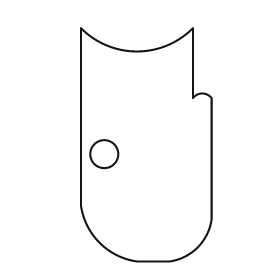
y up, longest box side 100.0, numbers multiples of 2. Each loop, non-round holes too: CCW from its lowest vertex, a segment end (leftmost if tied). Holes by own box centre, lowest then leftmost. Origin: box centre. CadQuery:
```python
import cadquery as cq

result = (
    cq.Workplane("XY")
    .moveTo(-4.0, -50.0)
    .lineTo(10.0, -50.0)
    .threePointArc((22.0, -44.0), (28.0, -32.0))
    .lineTo(28.0, 20.0)
    .threePointArc((24.0, 22.0), (20.0, 20.0))
    .lineTo(20.0, 50.0)
    .threePointArc((-4.0, 40.0), (-28.0, 50.0))
    .lineTo(-28.0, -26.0)
    .threePointArc((-20.0, -42.0), (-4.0, -50.0))
    .close()
    .moveTo(-18.0, -4.0)
    .circle(6.0)
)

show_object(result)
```